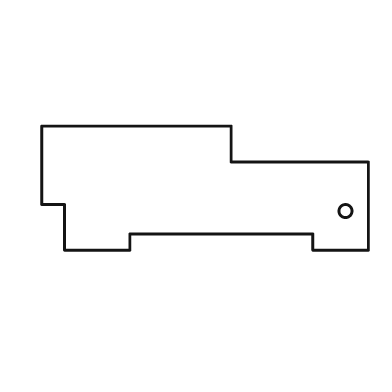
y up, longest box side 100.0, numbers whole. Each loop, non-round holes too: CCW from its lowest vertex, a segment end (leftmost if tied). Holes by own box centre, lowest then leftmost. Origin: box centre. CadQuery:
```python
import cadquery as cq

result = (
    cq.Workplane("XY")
    .moveTo(-43.0, -19.0)
    .lineTo(-23.0, -19.0)
    .lineTo(-23.0, -14.0)
    .lineTo(33.0, -14.0)
    .lineTo(33.0, -19.0)
    .lineTo(50.0, -19.0)
    .lineTo(50.0, 8.0)
    .lineTo(8.0, 8.0)
    .lineTo(8.0, 19.0)
    .lineTo(-50.0, 19.0)
    .lineTo(-50.0, -5.0)
    .lineTo(-43.0, -5.0)
    .close()
    .moveTo(43.0, -7.0)
    .circle(2.0)
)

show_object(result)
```